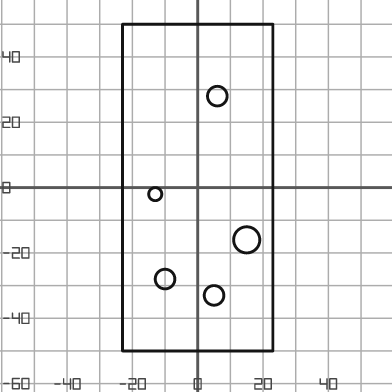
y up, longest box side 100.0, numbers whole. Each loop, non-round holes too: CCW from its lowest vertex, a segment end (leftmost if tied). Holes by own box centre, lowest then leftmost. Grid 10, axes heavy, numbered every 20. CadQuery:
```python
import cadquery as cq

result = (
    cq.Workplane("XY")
    .moveTo(-23.0, -50.0)
    .lineTo(23.0, -50.0)
    .lineTo(23.0, 50.0)
    .lineTo(-23.0, 50.0)
    .close()
    .moveTo(5.0, -33.0)
    .circle(3.0)
    .moveTo(-10.0, -28.0)
    .circle(3.0)
    .moveTo(15.0, -16.0)
    .circle(4.0)
    .moveTo(-13.0, -2.0)
    .circle(2.0)
    .moveTo(6.0, 28.0)
    .circle(3.0)
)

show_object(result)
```